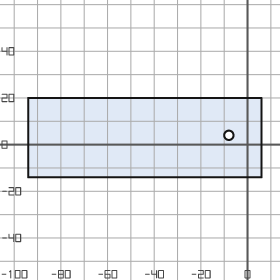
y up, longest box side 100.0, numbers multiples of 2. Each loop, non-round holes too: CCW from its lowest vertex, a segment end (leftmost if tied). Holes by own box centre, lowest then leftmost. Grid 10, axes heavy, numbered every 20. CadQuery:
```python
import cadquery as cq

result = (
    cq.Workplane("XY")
    .moveTo(-94.0, -14.0)
    .lineTo(6.0, -14.0)
    .lineTo(6.0, 20.0)
    .lineTo(-94.0, 20.0)
    .close()
    .moveTo(-8.0, 4.0)
    .circle(2.0)
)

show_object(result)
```